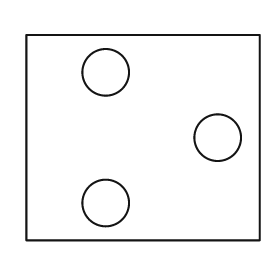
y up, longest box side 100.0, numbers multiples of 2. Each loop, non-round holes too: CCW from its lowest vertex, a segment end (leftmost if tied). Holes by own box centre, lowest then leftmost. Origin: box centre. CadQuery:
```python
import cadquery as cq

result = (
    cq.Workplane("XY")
    .moveTo(-50.0, -44.0)
    .lineTo(50.0, -44.0)
    .lineTo(50.0, 44.0)
    .lineTo(-50.0, 44.0)
    .close()
    .moveTo(-16.0, -28.0)
    .circle(10.0)
    .moveTo(32.0, 0.0)
    .circle(10.0)
    .moveTo(-16.0, 28.0)
    .circle(10.0)
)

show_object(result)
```